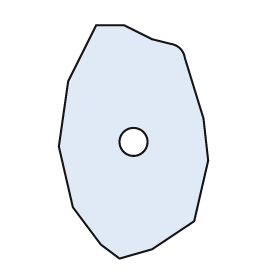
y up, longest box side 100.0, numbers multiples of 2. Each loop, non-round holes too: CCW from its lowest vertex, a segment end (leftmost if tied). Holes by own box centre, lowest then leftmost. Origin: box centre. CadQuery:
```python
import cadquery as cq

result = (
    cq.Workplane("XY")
    .moveTo(-6.0, -50.0)
    .lineTo(8.0, -46.0)
    .lineTo(26.0, -34.0)
    .lineTo(32.0, -8.0)
    .lineTo(30.0, 10.0)
    .lineTo(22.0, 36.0)
    .threePointArc((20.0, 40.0), (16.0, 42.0))
    .lineTo(8.0, 44.0)
    .lineTo(-4.0, 50.0)
    .lineTo(-16.0, 50.0)
    .lineTo(-28.0, 26.0)
    .lineTo(-32.0, -2.0)
    .lineTo(-26.0, -28.0)
    .lineTo(-14.0, -44.0)
    .close()
    .moveTo(0.0, 0.0)
    .circle(6.0)
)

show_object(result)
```